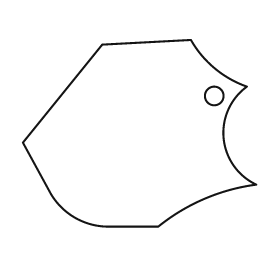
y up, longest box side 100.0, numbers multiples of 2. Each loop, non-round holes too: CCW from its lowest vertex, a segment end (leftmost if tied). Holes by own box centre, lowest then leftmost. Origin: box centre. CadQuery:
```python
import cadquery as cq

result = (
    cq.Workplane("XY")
    .moveTo(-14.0, -40.0)
    .lineTo(8.0, -40.0)
    .threePointArc((28.0, -28.0), (50.0, -22.0))
    .threePointArc((36.0, -2.0), (46.0, 20.0))
    .threePointArc((32.0, 28.0), (22.0, 40.0))
    .lineTo(-16.0, 38.0)
    .lineTo(-50.0, -4.0)
    .lineTo(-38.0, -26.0)
    .threePointArc((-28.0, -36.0), (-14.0, -40.0))
    .close()
    .moveTo(32.0, 16.0)
    .circle(4.0)
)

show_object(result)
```